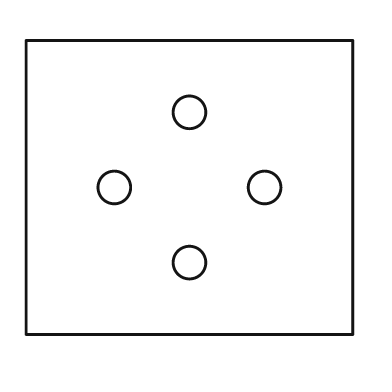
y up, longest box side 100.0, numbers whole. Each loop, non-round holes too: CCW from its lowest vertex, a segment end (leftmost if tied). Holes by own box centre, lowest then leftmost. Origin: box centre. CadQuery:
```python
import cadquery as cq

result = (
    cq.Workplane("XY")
    .moveTo(-50.0, -45.0)
    .lineTo(50.0, -45.0)
    .lineTo(50.0, 45.0)
    .lineTo(-50.0, 45.0)
    .close()
    .moveTo(0.0, -23.0)
    .circle(5.0)
    .moveTo(-23.0, 0.0)
    .circle(5.0)
    .moveTo(23.0, 0.0)
    .circle(5.0)
    .moveTo(0.0, 23.0)
    .circle(5.0)
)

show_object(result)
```